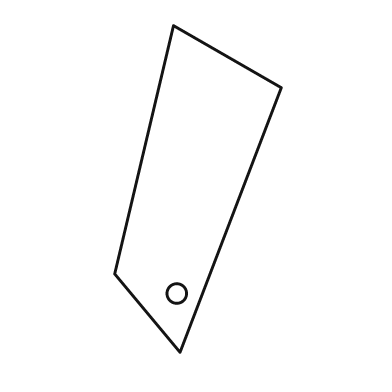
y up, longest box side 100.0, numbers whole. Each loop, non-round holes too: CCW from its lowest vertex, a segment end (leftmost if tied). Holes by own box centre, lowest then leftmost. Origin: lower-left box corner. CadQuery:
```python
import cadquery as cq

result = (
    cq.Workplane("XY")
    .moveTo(20.0, 0.0)
    .lineTo(51.0, 81.0)
    .lineTo(18.0, 100.0)
    .lineTo(0.0, 24.0)
    .close()
    .moveTo(19.0, 18.0)
    .circle(3.0)
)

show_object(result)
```